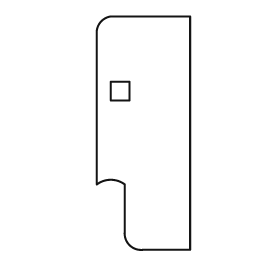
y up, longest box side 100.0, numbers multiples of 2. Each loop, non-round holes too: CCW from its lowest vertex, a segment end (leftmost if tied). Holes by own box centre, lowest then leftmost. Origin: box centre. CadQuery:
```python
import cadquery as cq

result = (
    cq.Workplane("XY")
    .moveTo(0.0, -50.0)
    .lineTo(20.0, -50.0)
    .lineTo(20.0, 50.0)
    .lineTo(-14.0, 50.0)
    .threePointArc((-18.0, 48.0), (-20.0, 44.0))
    .lineTo(-20.0, -22.0)
    .threePointArc((-14.0, -20.0), (-8.0, -22.0))
    .lineTo(-8.0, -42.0)
    .threePointArc((-6.0, -48.0), (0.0, -50.0))
    .close()
    .moveTo(-14.0, 14.0)
    .lineTo(-6.0, 14.0)
    .lineTo(-6.0, 22.0)
    .lineTo(-14.0, 22.0)
    .close()
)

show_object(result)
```